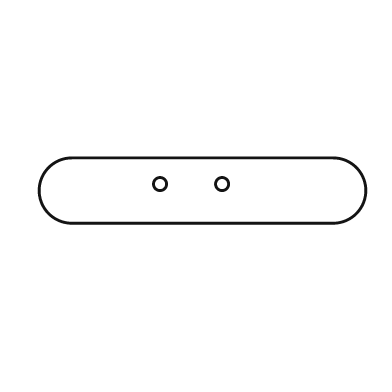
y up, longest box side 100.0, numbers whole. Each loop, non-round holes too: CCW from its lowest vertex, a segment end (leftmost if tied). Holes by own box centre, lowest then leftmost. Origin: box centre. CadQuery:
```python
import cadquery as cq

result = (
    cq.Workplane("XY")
    .moveTo(-40.0, -10.0)
    .lineTo(40.0, -10.0)
    .threePointArc((50.0, 0.0), (40.0, 10.0))
    .lineTo(-40.0, 10.0)
    .threePointArc((-50.0, 0.0), (-40.0, -10.0))
    .close()
    .moveTo(-13.0, 2.0)
    .circle(2.0)
    .moveTo(6.0, 2.0)
    .circle(2.0)
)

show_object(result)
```